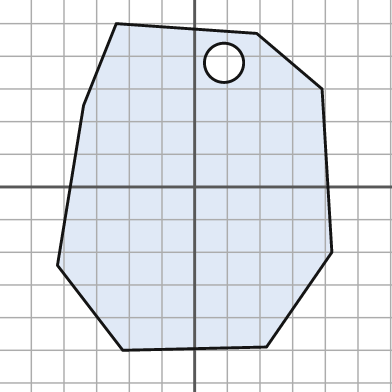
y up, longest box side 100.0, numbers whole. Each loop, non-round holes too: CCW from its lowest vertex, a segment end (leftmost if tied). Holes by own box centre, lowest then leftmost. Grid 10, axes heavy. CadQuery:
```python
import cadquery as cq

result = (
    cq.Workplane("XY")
    .moveTo(-22.0, -50.0)
    .lineTo(22.0, -49.0)
    .lineTo(42.0, -20.0)
    .lineTo(39.0, 30.0)
    .lineTo(19.0, 47.0)
    .lineTo(-24.0, 50.0)
    .lineTo(-34.0, 25.0)
    .lineTo(-42.0, -24.0)
    .close()
    .moveTo(9.0, 38.0)
    .circle(6.0)
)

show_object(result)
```